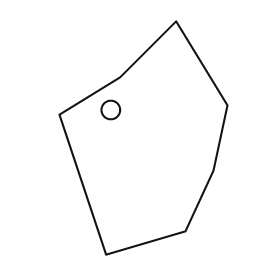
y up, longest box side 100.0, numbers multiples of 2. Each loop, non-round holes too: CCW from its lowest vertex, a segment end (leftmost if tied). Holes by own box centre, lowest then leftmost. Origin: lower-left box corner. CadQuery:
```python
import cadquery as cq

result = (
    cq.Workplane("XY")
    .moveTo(20.0, 0.0)
    .lineTo(54.0, 10.0)
    .lineTo(66.0, 36.0)
    .lineTo(72.0, 64.0)
    .lineTo(50.0, 100.0)
    .lineTo(26.0, 76.0)
    .lineTo(0.0, 60.0)
    .close()
    .moveTo(22.0, 62.0)
    .circle(4.0)
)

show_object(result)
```